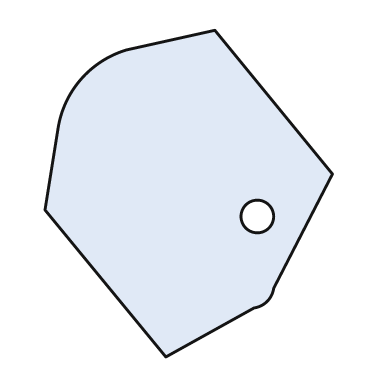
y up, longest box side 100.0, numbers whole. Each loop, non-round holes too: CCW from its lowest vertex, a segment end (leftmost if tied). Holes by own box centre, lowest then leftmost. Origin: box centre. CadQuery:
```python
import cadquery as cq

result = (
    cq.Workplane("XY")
    .moveTo(-7.0, -50.0)
    .lineTo(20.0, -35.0)
    .threePointArc((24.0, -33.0), (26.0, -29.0))
    .lineTo(44.0, 6.0)
    .lineTo(8.0, 50.0)
    .lineTo(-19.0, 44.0)
    .threePointArc((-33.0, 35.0), (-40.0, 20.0))
    .lineTo(-44.0, -5.0)
    .close()
    .moveTo(21.0, -7.0)
    .circle(5.0)
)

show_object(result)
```